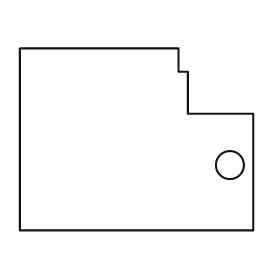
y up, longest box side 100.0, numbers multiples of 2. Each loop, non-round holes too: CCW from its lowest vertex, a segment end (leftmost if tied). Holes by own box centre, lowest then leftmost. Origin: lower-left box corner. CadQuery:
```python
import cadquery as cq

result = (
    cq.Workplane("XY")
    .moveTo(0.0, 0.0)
    .lineTo(100.0, 0.0)
    .lineTo(100.0, 50.0)
    .lineTo(72.0, 50.0)
    .lineTo(72.0, 68.0)
    .lineTo(68.0, 68.0)
    .lineTo(68.0, 78.0)
    .lineTo(0.0, 78.0)
    .close()
    .moveTo(90.0, 28.0)
    .circle(6.0)
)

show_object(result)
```